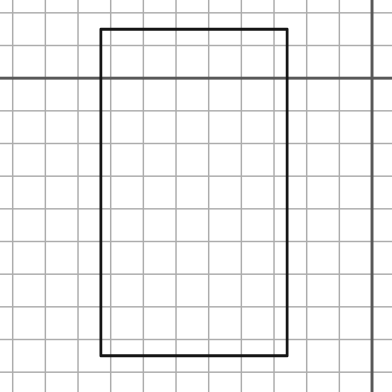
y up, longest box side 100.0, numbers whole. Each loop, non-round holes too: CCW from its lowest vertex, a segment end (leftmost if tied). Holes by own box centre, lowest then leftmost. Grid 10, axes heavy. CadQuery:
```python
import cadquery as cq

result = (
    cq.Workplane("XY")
    .moveTo(-83.0, -85.0)
    .lineTo(-26.0, -85.0)
    .lineTo(-26.0, 15.0)
    .lineTo(-83.0, 15.0)
    .close()
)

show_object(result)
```